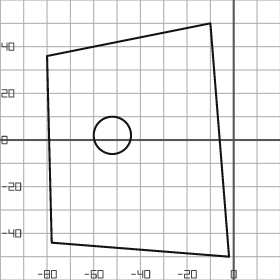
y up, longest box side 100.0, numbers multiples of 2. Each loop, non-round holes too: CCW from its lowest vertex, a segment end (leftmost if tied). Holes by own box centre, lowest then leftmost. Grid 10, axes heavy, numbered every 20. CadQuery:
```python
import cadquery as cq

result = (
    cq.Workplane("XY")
    .moveTo(-2.0, -50.0)
    .lineTo(-10.0, 50.0)
    .lineTo(-80.0, 36.0)
    .lineTo(-78.0, -44.0)
    .close()
    .moveTo(-52.0, 2.0)
    .circle(8.0)
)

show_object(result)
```